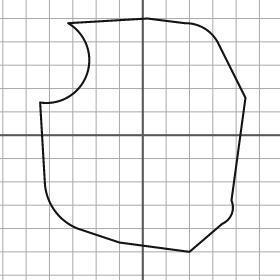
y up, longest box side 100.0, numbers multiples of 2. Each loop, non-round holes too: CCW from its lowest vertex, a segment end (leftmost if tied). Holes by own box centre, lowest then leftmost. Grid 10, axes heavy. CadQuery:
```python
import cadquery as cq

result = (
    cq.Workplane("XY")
    .moveTo(20.0, -50.0)
    .lineTo(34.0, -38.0)
    .threePointArc((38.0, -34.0), (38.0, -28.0))
    .lineTo(44.0, 16.0)
    .lineTo(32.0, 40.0)
    .threePointArc((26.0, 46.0), (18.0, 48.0))
    .lineTo(2.0, 50.0)
    .lineTo(-32.0, 48.0)
    .threePointArc((-24.0, 26.0), (-44.0, 14.0))
    .lineTo(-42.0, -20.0)
    .threePointArc((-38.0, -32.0), (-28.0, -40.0))
    .lineTo(-10.0, -46.0)
    .close()
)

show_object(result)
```